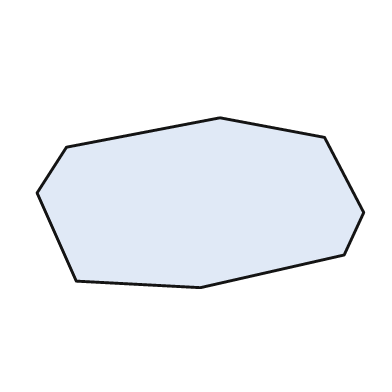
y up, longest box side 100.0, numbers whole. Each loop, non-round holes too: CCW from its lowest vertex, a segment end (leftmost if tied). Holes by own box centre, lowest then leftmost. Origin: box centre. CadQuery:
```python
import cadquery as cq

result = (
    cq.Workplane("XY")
    .moveTo(0.0, -26.0)
    .lineTo(44.0, -16.0)
    .lineTo(50.0, -3.0)
    .lineTo(38.0, 20.0)
    .lineTo(6.0, 26.0)
    .lineTo(-41.0, 17.0)
    .lineTo(-50.0, 3.0)
    .lineTo(-38.0, -24.0)
    .close()
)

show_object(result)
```